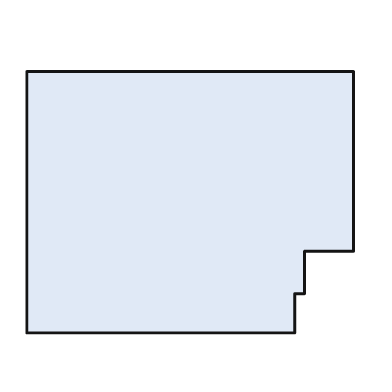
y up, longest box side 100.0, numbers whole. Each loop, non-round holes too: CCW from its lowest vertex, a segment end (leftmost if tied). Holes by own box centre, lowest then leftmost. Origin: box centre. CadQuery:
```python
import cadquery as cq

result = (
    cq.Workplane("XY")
    .moveTo(-50.0, -40.0)
    .lineTo(32.0, -40.0)
    .lineTo(32.0, -28.0)
    .lineTo(35.0, -28.0)
    .lineTo(35.0, -15.0)
    .lineTo(50.0, -15.0)
    .lineTo(50.0, 40.0)
    .lineTo(-50.0, 40.0)
    .close()
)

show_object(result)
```